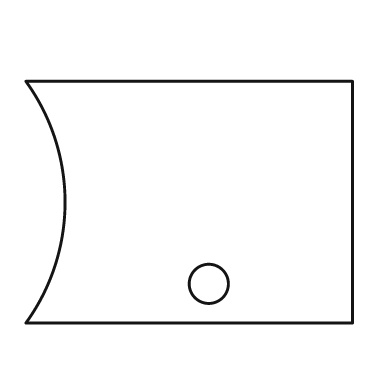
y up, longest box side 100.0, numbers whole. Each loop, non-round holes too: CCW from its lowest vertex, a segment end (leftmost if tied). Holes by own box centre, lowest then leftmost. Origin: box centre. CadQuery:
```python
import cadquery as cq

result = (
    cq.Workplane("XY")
    .moveTo(-50.0, -37.0)
    .lineTo(50.0, -37.0)
    .lineTo(50.0, 37.0)
    .lineTo(-50.0, 37.0)
    .threePointArc((-38.0, 0.0), (-50.0, -37.0))
    .close()
    .moveTo(6.0, -25.0)
    .circle(6.0)
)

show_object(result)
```